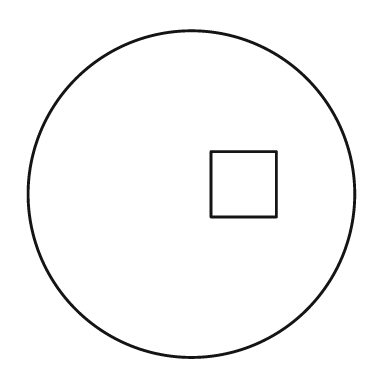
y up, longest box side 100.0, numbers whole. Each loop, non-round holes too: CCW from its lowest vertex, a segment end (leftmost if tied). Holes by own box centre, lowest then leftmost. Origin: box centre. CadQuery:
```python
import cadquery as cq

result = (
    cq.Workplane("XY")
    .moveTo(0.0, 0.0)
    .circle(50.0)
    .moveTo(6.0, -7.0)
    .lineTo(26.0, -7.0)
    .lineTo(26.0, 13.0)
    .lineTo(6.0, 13.0)
    .close()
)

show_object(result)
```